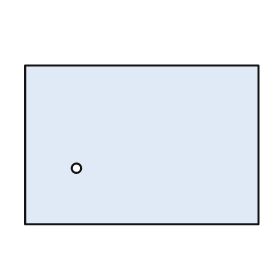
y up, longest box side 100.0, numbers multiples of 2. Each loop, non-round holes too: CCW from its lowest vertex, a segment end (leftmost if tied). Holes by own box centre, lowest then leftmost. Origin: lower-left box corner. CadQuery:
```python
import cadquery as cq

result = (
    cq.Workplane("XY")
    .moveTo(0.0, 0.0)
    .lineTo(100.0, 0.0)
    .lineTo(100.0, 68.0)
    .lineTo(0.0, 68.0)
    .close()
    .moveTo(22.0, 24.0)
    .circle(2.0)
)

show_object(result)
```